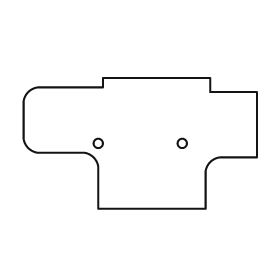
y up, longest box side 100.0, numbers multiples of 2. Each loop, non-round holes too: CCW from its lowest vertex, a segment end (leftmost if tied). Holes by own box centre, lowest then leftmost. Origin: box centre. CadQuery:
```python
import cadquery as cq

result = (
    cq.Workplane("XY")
    .moveTo(-18.0, -28.0)
    .lineTo(28.0, -28.0)
    .lineTo(28.0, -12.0)
    .threePointArc((30.0, -8.0), (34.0, -6.0))
    .lineTo(50.0, -6.0)
    .lineTo(50.0, 22.0)
    .lineTo(30.0, 22.0)
    .lineTo(30.0, 28.0)
    .lineTo(-16.0, 28.0)
    .lineTo(-16.0, 24.0)
    .lineTo(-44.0, 24.0)
    .threePointArc((-48.0, 22.0), (-50.0, 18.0))
    .lineTo(-50.0, 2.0)
    .threePointArc((-48.0, -2.0), (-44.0, -4.0))
    .lineTo(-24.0, -4.0)
    .threePointArc((-20.0, -6.0), (-18.0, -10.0))
    .close()
    .moveTo(-18.0, 0.0)
    .circle(2.0)
    .moveTo(18.0, 0.0)
    .circle(2.0)
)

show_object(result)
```